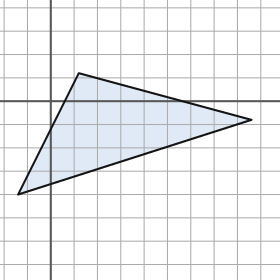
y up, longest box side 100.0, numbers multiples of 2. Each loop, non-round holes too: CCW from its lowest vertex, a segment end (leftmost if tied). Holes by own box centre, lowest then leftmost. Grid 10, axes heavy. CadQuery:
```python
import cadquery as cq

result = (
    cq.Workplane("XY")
    .moveTo(-14.0, -40.0)
    .lineTo(86.0, -8.0)
    .lineTo(12.0, 12.0)
    .close()
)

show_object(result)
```